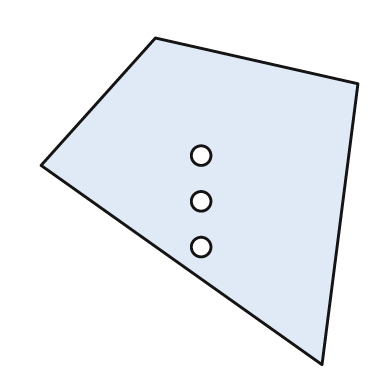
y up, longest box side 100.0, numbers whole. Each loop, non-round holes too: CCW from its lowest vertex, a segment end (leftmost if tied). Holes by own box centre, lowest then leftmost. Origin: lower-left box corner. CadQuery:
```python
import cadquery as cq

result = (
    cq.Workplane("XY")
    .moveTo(86.0, 0.0)
    .lineTo(97.0, 86.0)
    .lineTo(35.0, 100.0)
    .lineTo(0.0, 61.0)
    .close()
    .moveTo(49.0, 36.0)
    .circle(3.0)
    .moveTo(49.0, 50.0)
    .circle(3.0)
    .moveTo(49.0, 64.0)
    .circle(3.0)
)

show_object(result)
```